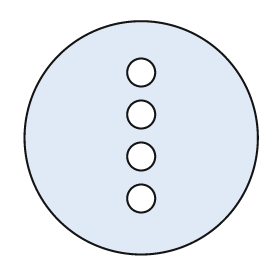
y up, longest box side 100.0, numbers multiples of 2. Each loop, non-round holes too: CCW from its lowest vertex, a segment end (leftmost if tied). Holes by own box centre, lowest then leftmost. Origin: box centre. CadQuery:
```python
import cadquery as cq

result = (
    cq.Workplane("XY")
    .moveTo(0.0, 0.0)
    .circle(50.0)
    .moveTo(0.0, -26.0)
    .circle(6.0)
    .moveTo(0.0, -8.0)
    .circle(6.0)
    .moveTo(0.0, 10.0)
    .circle(6.0)
    .moveTo(0.0, 28.0)
    .circle(6.0)
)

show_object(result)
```